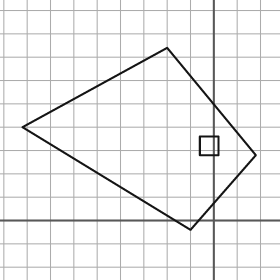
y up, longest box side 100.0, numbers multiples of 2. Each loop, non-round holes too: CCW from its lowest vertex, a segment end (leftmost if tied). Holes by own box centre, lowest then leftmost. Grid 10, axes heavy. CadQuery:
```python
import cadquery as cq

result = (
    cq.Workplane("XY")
    .moveTo(-10.0, -4.0)
    .lineTo(18.0, 28.0)
    .lineTo(-20.0, 74.0)
    .lineTo(-82.0, 40.0)
    .close()
    .moveTo(-6.0, 28.0)
    .lineTo(2.0, 28.0)
    .lineTo(2.0, 36.0)
    .lineTo(-6.0, 36.0)
    .close()
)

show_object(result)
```